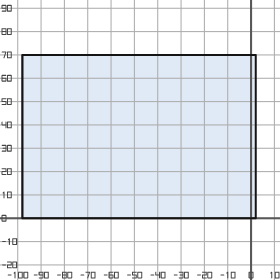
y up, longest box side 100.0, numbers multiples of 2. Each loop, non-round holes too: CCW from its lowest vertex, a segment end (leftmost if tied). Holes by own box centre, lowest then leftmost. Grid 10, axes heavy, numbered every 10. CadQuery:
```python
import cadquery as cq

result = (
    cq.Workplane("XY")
    .moveTo(-98.0, 0.0)
    .lineTo(2.0, 0.0)
    .lineTo(2.0, 70.0)
    .lineTo(-98.0, 70.0)
    .close()
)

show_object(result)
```